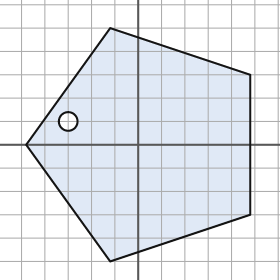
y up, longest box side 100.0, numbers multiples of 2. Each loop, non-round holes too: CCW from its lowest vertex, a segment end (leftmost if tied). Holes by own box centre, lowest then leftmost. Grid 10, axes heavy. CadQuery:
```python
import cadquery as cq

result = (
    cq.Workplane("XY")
    .moveTo(-12.0, -50.0)
    .lineTo(48.0, -30.0)
    .lineTo(48.0, 30.0)
    .lineTo(-12.0, 50.0)
    .lineTo(-48.0, 0.0)
    .close()
    .moveTo(-30.0, 10.0)
    .circle(4.0)
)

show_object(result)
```